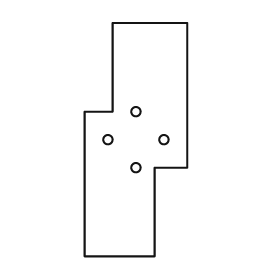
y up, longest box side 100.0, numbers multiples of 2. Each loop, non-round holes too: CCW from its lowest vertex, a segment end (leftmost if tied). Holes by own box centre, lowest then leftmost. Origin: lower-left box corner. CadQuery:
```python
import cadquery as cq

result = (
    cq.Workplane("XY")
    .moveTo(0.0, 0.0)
    .lineTo(30.0, 0.0)
    .lineTo(30.0, 38.0)
    .lineTo(44.0, 38.0)
    .lineTo(44.0, 100.0)
    .lineTo(12.0, 100.0)
    .lineTo(12.0, 62.0)
    .lineTo(0.0, 62.0)
    .close()
    .moveTo(22.0, 38.0)
    .circle(2.0)
    .moveTo(10.0, 50.0)
    .circle(2.0)
    .moveTo(34.0, 50.0)
    .circle(2.0)
    .moveTo(22.0, 62.0)
    .circle(2.0)
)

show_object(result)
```